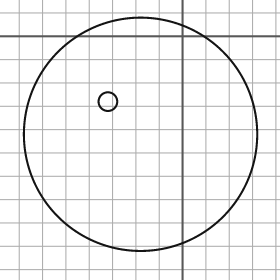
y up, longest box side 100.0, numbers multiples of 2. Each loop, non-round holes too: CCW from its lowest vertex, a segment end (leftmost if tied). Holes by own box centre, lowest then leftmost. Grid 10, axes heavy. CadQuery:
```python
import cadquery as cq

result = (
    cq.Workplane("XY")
    .moveTo(-18.0, -42.0)
    .circle(50.0)
    .moveTo(-32.0, -28.0)
    .circle(4.0)
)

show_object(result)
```